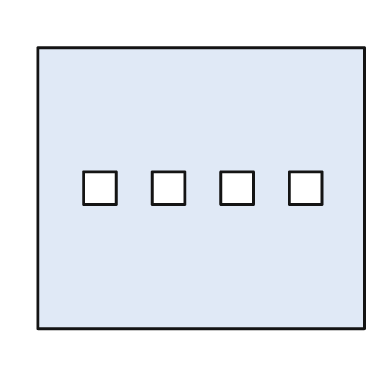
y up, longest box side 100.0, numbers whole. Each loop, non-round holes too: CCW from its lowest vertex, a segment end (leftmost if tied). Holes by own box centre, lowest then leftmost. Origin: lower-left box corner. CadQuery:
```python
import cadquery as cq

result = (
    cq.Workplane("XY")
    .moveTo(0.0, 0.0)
    .lineTo(100.0, 0.0)
    .lineTo(100.0, 86.0)
    .lineTo(0.0, 86.0)
    .close()
    .moveTo(14.0, 38.0)
    .lineTo(24.0, 38.0)
    .lineTo(24.0, 48.0)
    .lineTo(14.0, 48.0)
    .close()
    .moveTo(35.0, 38.0)
    .lineTo(45.0, 38.0)
    .lineTo(45.0, 48.0)
    .lineTo(35.0, 48.0)
    .close()
    .moveTo(56.0, 38.0)
    .lineTo(66.0, 38.0)
    .lineTo(66.0, 48.0)
    .lineTo(56.0, 48.0)
    .close()
    .moveTo(77.0, 38.0)
    .lineTo(87.0, 38.0)
    .lineTo(87.0, 48.0)
    .lineTo(77.0, 48.0)
    .close()
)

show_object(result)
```